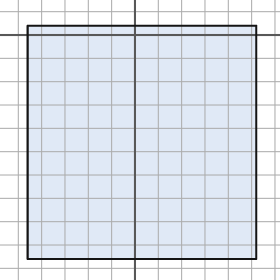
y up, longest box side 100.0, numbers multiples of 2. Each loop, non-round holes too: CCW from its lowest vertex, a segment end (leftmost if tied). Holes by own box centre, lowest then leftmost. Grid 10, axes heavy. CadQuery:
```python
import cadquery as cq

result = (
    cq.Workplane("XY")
    .moveTo(-46.0, -96.0)
    .lineTo(52.0, -96.0)
    .lineTo(52.0, 4.0)
    .lineTo(-46.0, 4.0)
    .close()
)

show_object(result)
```